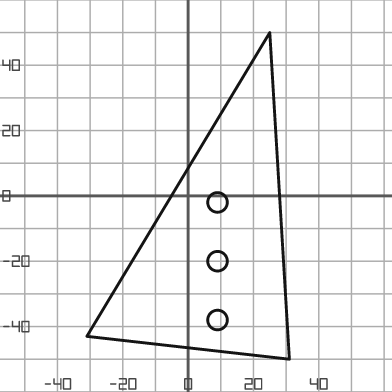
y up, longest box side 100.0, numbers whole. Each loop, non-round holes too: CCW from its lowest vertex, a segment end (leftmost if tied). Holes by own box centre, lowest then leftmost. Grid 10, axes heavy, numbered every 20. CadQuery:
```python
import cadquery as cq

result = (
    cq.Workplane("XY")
    .moveTo(31.0, -50.0)
    .lineTo(25.0, 50.0)
    .lineTo(-31.0, -43.0)
    .close()
    .moveTo(9.0, -38.0)
    .circle(3.0)
    .moveTo(9.0, -20.0)
    .circle(3.0)
    .moveTo(9.0, -2.0)
    .circle(3.0)
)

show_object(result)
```